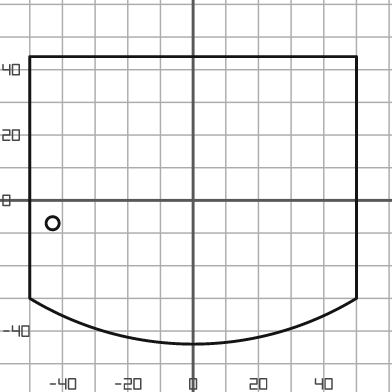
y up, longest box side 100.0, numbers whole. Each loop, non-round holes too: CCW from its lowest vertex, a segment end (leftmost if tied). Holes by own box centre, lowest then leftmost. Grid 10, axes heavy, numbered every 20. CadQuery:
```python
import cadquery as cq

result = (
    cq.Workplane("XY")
    .moveTo(-50.0, -30.0)
    .threePointArc((0.0, -44.0), (50.0, -30.0))
    .lineTo(50.0, 44.0)
    .lineTo(-50.0, 44.0)
    .close()
    .moveTo(-43.0, -7.0)
    .circle(2.0)
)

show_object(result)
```